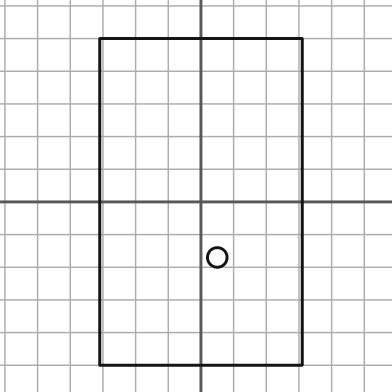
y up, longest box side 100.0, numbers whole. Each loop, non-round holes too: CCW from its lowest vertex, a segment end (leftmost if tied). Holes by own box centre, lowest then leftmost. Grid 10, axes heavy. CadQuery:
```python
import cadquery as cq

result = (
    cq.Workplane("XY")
    .moveTo(-31.0, -50.0)
    .lineTo(31.0, -50.0)
    .lineTo(31.0, 50.0)
    .lineTo(-31.0, 50.0)
    .close()
    .moveTo(5.0, -17.0)
    .circle(3.0)
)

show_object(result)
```